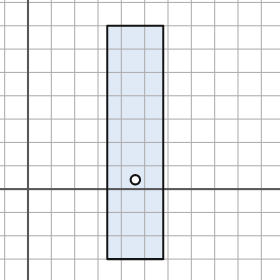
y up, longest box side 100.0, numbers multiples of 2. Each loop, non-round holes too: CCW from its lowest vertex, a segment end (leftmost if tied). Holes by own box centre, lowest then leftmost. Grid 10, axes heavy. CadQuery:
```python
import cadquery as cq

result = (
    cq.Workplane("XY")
    .moveTo(34.0, -30.0)
    .lineTo(58.0, -30.0)
    .lineTo(58.0, 70.0)
    .lineTo(34.0, 70.0)
    .close()
    .moveTo(46.0, 4.0)
    .circle(2.0)
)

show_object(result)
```